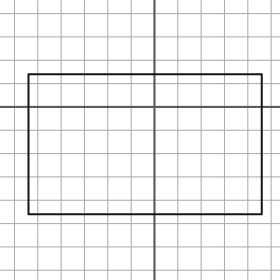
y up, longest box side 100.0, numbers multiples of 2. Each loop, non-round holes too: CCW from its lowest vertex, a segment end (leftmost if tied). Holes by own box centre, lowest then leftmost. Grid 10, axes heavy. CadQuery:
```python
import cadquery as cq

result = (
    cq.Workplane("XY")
    .moveTo(-54.0, -46.0)
    .lineTo(46.0, -46.0)
    .lineTo(46.0, 14.0)
    .lineTo(-54.0, 14.0)
    .close()
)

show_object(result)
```